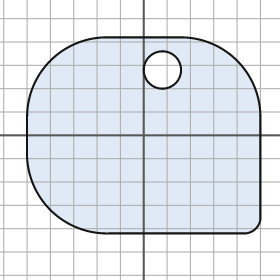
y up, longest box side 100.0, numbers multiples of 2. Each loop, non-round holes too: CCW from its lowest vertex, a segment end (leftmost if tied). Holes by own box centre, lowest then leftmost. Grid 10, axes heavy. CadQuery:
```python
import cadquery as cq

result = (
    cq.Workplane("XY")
    .moveTo(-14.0, -42.0)
    .lineTo(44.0, -42.0)
    .threePointArc((48.0, -40.0), (50.0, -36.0))
    .lineTo(50.0, 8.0)
    .threePointArc((40.0, 32.0), (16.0, 42.0))
    .lineTo(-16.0, 42.0)
    .threePointArc((-40.0, 32.0), (-50.0, 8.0))
    .lineTo(-50.0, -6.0)
    .threePointArc((-40.0, -32.0), (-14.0, -42.0))
    .close()
    .moveTo(8.0, 28.0)
    .circle(8.0)
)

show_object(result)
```